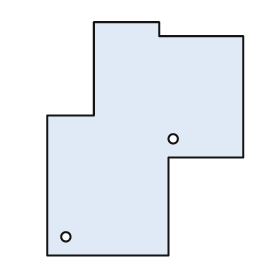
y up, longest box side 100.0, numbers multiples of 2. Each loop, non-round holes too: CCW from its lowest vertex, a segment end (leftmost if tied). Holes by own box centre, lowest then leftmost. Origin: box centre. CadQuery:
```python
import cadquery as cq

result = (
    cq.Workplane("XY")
    .moveTo(-42.0, -50.0)
    .lineTo(10.0, -50.0)
    .lineTo(10.0, -8.0)
    .lineTo(42.0, -8.0)
    .lineTo(42.0, 44.0)
    .lineTo(6.0, 44.0)
    .lineTo(6.0, 50.0)
    .lineTo(-22.0, 50.0)
    .lineTo(-22.0, 10.0)
    .lineTo(-42.0, 10.0)
    .close()
    .moveTo(-34.0, -42.0)
    .circle(2.0)
    .moveTo(12.0, 0.0)
    .circle(2.0)
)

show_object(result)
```